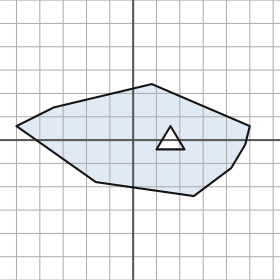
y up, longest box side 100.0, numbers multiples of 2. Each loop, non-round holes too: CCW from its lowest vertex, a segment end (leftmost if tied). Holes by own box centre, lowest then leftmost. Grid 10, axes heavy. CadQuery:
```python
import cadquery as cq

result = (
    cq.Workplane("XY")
    .moveTo(26.0, -24.0)
    .lineTo(42.0, -12.0)
    .lineTo(48.0, -2.0)
    .lineTo(50.0, 6.0)
    .lineTo(8.0, 24.0)
    .lineTo(-34.0, 14.0)
    .lineTo(-50.0, 6.0)
    .lineTo(-16.0, -18.0)
    .close()
    .moveTo(10.0, -4.0)
    .lineTo(22.0, -4.0)
    .lineTo(16.0, 6.0)
    .close()
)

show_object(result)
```